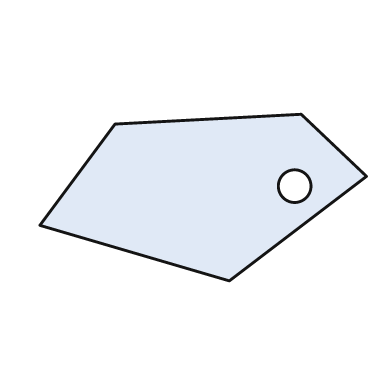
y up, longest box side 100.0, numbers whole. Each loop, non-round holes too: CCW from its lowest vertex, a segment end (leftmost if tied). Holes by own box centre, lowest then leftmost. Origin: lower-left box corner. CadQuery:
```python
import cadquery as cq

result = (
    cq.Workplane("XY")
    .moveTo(58.0, 0.0)
    .lineTo(100.0, 32.0)
    .lineTo(80.0, 51.0)
    .lineTo(23.0, 48.0)
    .lineTo(0.0, 17.0)
    .close()
    .moveTo(78.0, 29.0)
    .circle(5.0)
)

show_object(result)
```